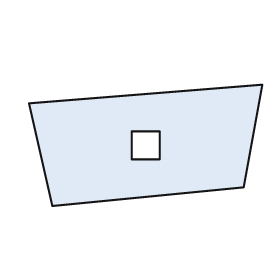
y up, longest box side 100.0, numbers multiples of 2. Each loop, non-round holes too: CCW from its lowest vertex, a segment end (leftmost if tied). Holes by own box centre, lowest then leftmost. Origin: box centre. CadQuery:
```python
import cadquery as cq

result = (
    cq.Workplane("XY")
    .moveTo(-40.0, -26.0)
    .lineTo(42.0, -18.0)
    .lineTo(50.0, 26.0)
    .lineTo(-50.0, 18.0)
    .close()
    .moveTo(-6.0, -6.0)
    .lineTo(6.0, -6.0)
    .lineTo(6.0, 6.0)
    .lineTo(-6.0, 6.0)
    .close()
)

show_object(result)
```